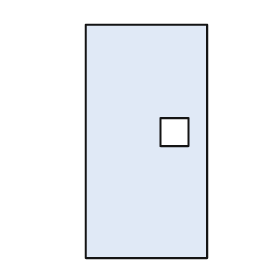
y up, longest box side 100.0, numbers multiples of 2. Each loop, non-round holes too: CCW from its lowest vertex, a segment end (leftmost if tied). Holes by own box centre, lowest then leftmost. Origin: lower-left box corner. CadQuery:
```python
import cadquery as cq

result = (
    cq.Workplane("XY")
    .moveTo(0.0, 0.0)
    .lineTo(52.0, 0.0)
    .lineTo(52.0, 100.0)
    .lineTo(0.0, 100.0)
    .close()
    .moveTo(32.0, 48.0)
    .lineTo(44.0, 48.0)
    .lineTo(44.0, 60.0)
    .lineTo(32.0, 60.0)
    .close()
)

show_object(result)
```